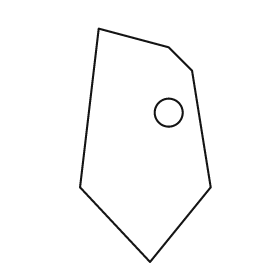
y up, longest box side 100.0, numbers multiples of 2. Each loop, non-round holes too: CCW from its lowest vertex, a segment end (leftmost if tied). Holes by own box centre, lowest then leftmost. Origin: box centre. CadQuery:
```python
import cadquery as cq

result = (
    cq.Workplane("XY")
    .moveTo(2.0, -50.0)
    .lineTo(28.0, -18.0)
    .lineTo(20.0, 32.0)
    .lineTo(10.0, 42.0)
    .lineTo(-20.0, 50.0)
    .lineTo(-28.0, -18.0)
    .close()
    .moveTo(10.0, 14.0)
    .circle(6.0)
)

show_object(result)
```